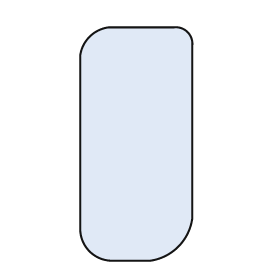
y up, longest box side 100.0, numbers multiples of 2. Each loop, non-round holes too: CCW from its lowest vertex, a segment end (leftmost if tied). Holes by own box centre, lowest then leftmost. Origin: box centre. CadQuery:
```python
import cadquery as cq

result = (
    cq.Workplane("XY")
    .moveTo(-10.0, -50.0)
    .lineTo(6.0, -50.0)
    .threePointArc((18.0, -44.0), (24.0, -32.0))
    .lineTo(24.0, 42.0)
    .threePointArc((22.0, 48.0), (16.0, 50.0))
    .lineTo(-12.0, 50.0)
    .threePointArc((-20.0, 46.0), (-24.0, 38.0))
    .lineTo(-24.0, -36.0)
    .threePointArc((-20.0, -46.0), (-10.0, -50.0))
    .close()
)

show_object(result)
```